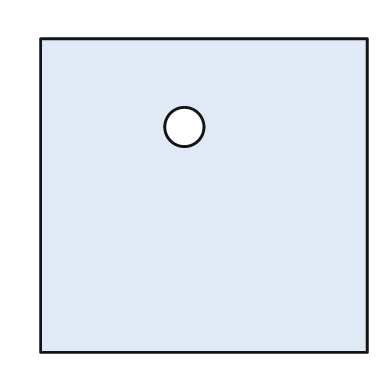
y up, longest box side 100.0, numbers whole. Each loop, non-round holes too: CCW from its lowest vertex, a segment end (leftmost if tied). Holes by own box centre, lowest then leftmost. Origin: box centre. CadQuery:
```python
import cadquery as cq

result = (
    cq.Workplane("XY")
    .moveTo(-50.0, -48.0)
    .lineTo(50.0, -48.0)
    .lineTo(50.0, 48.0)
    .lineTo(-50.0, 48.0)
    .close()
    .moveTo(-6.0, 21.0)
    .circle(6.0)
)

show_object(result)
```